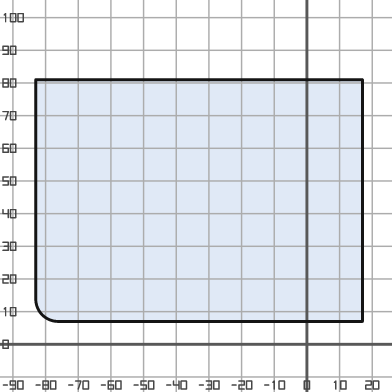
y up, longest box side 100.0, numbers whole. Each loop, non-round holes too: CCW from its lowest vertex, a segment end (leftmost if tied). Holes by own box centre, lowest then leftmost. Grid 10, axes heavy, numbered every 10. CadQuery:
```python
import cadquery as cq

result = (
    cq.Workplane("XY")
    .moveTo(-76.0, 7.0)
    .lineTo(17.0, 7.0)
    .lineTo(17.0, 81.0)
    .lineTo(-83.0, 81.0)
    .lineTo(-83.0, 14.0)
    .threePointArc((-81.0, 9.0), (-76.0, 7.0))
    .close()
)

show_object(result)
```